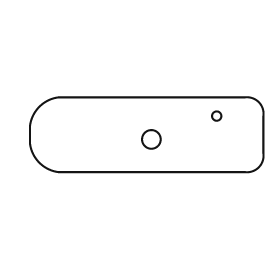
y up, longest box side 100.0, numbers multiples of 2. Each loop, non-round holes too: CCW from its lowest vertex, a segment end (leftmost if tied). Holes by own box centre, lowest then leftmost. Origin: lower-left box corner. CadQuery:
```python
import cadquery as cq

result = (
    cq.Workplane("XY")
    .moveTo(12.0, 0.0)
    .lineTo(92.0, 0.0)
    .threePointArc((98.0, 2.0), (100.0, 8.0))
    .lineTo(100.0, 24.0)
    .threePointArc((98.0, 30.0), (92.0, 32.0))
    .lineTo(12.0, 32.0)
    .threePointArc((4.0, 28.0), (0.0, 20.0))
    .lineTo(0.0, 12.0)
    .threePointArc((4.0, 4.0), (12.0, 0.0))
    .close()
    .moveTo(52.0, 14.0)
    .circle(4.0)
    .moveTo(80.0, 24.0)
    .circle(2.0)
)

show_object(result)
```